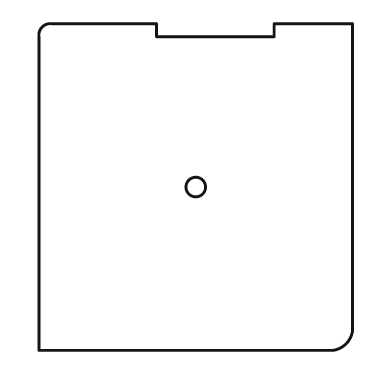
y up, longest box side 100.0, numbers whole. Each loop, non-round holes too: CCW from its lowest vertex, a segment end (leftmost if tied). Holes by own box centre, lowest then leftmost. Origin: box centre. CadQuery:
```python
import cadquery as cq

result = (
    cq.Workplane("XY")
    .moveTo(-48.0, -50.0)
    .lineTo(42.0, -50.0)
    .threePointArc((46.0, -48.0), (48.0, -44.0))
    .lineTo(48.0, 50.0)
    .lineTo(24.0, 50.0)
    .lineTo(24.0, 46.0)
    .lineTo(-12.0, 46.0)
    .lineTo(-12.0, 50.0)
    .lineTo(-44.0, 50.0)
    .threePointArc((-47.0, 49.0), (-48.0, 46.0))
    .close()
    .moveTo(0.0, 0.0)
    .circle(3.0)
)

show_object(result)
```